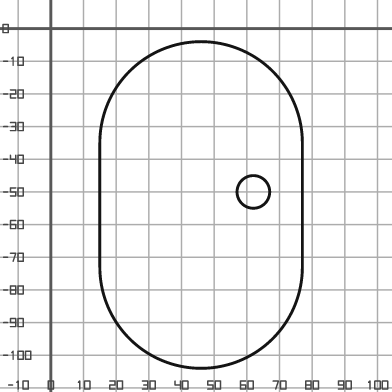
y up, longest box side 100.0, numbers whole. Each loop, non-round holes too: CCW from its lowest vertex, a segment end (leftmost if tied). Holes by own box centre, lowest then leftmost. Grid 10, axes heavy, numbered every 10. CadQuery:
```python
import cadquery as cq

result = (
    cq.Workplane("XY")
    .moveTo(15.0, -73.0)
    .threePointArc((46.0, -104.0), (77.0, -73.0))
    .lineTo(77.0, -35.0)
    .threePointArc((46.0, -4.0), (15.0, -35.0))
    .close()
    .moveTo(62.0, -50.0)
    .circle(5.0)
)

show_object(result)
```